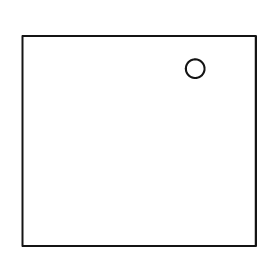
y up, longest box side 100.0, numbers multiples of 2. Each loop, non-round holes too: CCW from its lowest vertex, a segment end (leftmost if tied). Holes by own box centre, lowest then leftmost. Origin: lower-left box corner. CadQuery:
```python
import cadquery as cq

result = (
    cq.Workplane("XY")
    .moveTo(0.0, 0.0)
    .lineTo(100.0, 0.0)
    .lineTo(100.0, 90.0)
    .lineTo(0.0, 90.0)
    .close()
    .moveTo(74.0, 76.0)
    .circle(4.0)
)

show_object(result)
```